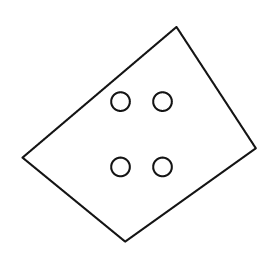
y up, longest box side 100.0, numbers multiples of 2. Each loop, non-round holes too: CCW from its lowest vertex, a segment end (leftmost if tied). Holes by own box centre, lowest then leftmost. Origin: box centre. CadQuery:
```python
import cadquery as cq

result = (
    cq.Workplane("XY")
    .moveTo(-6.0, -46.0)
    .lineTo(50.0, -6.0)
    .lineTo(16.0, 46.0)
    .lineTo(-50.0, -10.0)
    .close()
    .moveTo(-8.0, -14.0)
    .circle(4.0)
    .moveTo(10.0, -14.0)
    .circle(4.0)
    .moveTo(-8.0, 14.0)
    .circle(4.0)
    .moveTo(10.0, 14.0)
    .circle(4.0)
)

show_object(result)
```